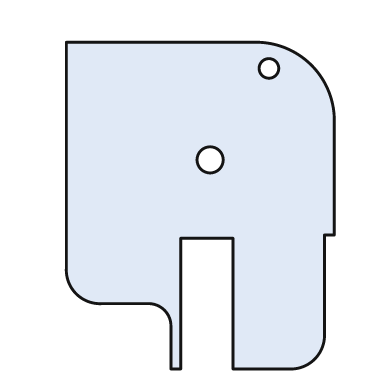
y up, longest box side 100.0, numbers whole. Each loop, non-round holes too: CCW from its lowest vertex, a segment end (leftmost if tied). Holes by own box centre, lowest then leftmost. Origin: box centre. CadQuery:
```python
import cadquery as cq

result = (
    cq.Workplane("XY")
    .moveTo(-9.0, -50.0)
    .lineTo(-6.0, -50.0)
    .lineTo(-6.0, -10.0)
    .lineTo(10.0, -10.0)
    .lineTo(10.0, -50.0)
    .lineTo(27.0, -50.0)
    .threePointArc((35.0, -47.0), (38.0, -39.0))
    .lineTo(38.0, -9.0)
    .lineTo(41.0, -9.0)
    .lineTo(41.0, 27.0)
    .threePointArc((34.0, 43.0), (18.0, 50.0))
    .lineTo(-41.0, 50.0)
    .lineTo(-41.0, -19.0)
    .threePointArc((-38.0, -27.0), (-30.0, -30.0))
    .lineTo(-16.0, -30.0)
    .threePointArc((-11.0, -32.0), (-9.0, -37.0))
    .close()
    .moveTo(3.0, 14.0)
    .circle(4.0)
    .moveTo(21.0, 42.0)
    .circle(3.0)
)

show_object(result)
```